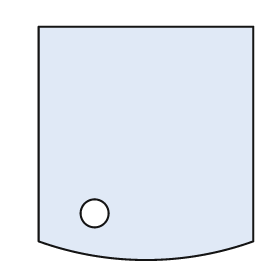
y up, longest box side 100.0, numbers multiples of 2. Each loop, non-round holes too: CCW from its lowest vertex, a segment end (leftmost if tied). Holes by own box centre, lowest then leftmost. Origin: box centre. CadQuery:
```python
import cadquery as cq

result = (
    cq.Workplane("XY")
    .moveTo(-46.0, -42.0)
    .threePointArc((0.0, -50.0), (46.0, -42.0))
    .lineTo(46.0, 50.0)
    .lineTo(-46.0, 50.0)
    .close()
    .moveTo(-22.0, -30.0)
    .circle(6.0)
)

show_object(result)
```